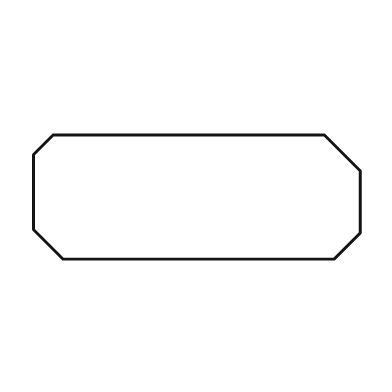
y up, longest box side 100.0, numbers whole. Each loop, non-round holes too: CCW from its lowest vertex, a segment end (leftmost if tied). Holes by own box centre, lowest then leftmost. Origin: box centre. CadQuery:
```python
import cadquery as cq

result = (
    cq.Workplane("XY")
    .moveTo(-41.0, -19.0)
    .lineTo(42.0, -19.0)
    .lineTo(50.0, -11.0)
    .lineTo(50.0, 8.0)
    .lineTo(39.0, 19.0)
    .lineTo(-44.0, 19.0)
    .lineTo(-50.0, 13.0)
    .lineTo(-50.0, -10.0)
    .close()
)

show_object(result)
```